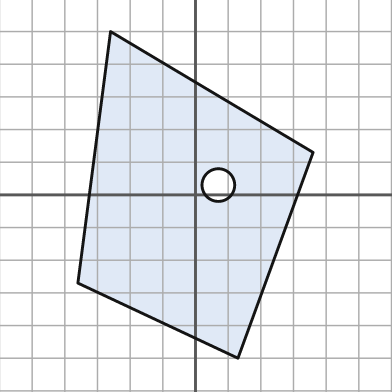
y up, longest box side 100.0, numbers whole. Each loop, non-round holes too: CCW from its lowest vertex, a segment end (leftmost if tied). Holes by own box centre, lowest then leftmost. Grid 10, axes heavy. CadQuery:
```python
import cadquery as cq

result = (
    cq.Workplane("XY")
    .moveTo(13.0, -50.0)
    .lineTo(36.0, 13.0)
    .lineTo(-26.0, 50.0)
    .lineTo(-36.0, -27.0)
    .close()
    .moveTo(7.0, 3.0)
    .circle(5.0)
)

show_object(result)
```